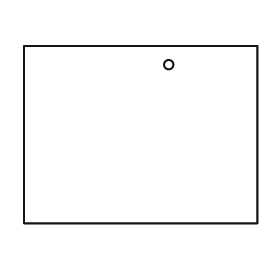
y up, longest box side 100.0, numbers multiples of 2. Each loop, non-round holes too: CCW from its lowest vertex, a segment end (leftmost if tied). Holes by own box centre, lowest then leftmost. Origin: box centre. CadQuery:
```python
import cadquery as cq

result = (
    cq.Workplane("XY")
    .moveTo(-50.0, -38.0)
    .lineTo(50.0, -38.0)
    .lineTo(50.0, 38.0)
    .lineTo(-50.0, 38.0)
    .close()
    .moveTo(12.0, 30.0)
    .circle(2.0)
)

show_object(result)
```